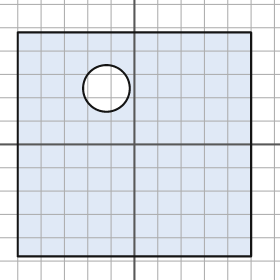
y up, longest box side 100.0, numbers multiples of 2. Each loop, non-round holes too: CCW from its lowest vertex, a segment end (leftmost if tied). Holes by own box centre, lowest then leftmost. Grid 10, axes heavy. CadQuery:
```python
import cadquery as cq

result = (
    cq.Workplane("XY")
    .moveTo(-50.0, -48.0)
    .lineTo(50.0, -48.0)
    .lineTo(50.0, 48.0)
    .lineTo(-50.0, 48.0)
    .close()
    .moveTo(-12.0, 24.0)
    .circle(10.0)
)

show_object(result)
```